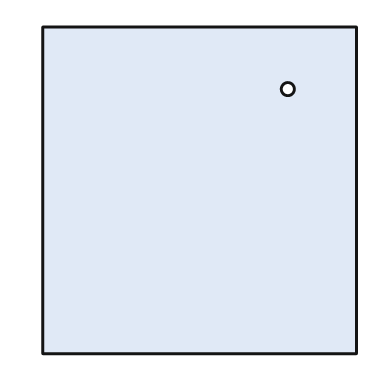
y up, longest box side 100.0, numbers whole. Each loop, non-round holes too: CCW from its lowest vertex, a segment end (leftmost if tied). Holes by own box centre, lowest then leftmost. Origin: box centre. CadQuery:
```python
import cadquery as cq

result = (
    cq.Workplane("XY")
    .moveTo(-48.0, -50.0)
    .lineTo(48.0, -50.0)
    .lineTo(48.0, 50.0)
    .lineTo(-48.0, 50.0)
    .close()
    .moveTo(27.0, 31.0)
    .circle(2.0)
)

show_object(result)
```